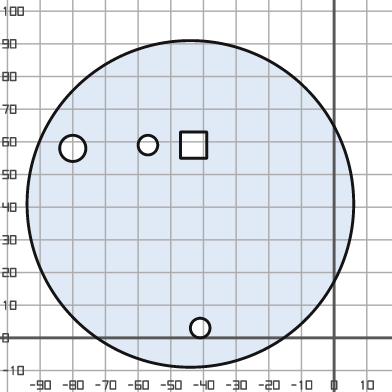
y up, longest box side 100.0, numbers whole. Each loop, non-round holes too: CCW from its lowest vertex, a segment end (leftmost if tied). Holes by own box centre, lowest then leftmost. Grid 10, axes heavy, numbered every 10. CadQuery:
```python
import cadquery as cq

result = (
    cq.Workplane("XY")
    .moveTo(-44.0, 41.0)
    .circle(50.0)
    .moveTo(-41.0, 3.0)
    .circle(3.0)
    .moveTo(-80.0, 58.0)
    .circle(4.0)
    .moveTo(-57.0, 59.0)
    .circle(3.0)
    .moveTo(-47.0, 55.0)
    .lineTo(-39.0, 55.0)
    .lineTo(-39.0, 63.0)
    .lineTo(-47.0, 63.0)
    .close()
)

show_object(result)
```